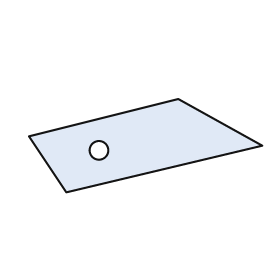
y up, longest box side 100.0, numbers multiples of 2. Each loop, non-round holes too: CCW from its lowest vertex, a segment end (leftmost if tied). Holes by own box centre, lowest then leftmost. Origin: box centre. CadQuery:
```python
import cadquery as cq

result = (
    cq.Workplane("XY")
    .moveTo(-34.0, -20.0)
    .lineTo(50.0, 0.0)
    .lineTo(14.0, 20.0)
    .lineTo(-50.0, 4.0)
    .close()
    .moveTo(-20.0, -2.0)
    .circle(4.0)
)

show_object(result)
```